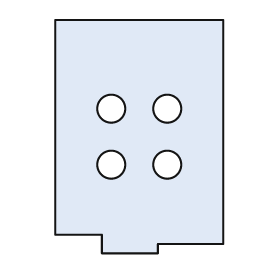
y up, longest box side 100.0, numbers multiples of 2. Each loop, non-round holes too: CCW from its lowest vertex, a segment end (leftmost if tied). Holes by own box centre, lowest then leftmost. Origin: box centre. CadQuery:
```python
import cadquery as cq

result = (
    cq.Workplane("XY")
    .moveTo(-16.0, -50.0)
    .lineTo(8.0, -50.0)
    .lineTo(8.0, -46.0)
    .lineTo(36.0, -46.0)
    .lineTo(36.0, 50.0)
    .lineTo(-36.0, 50.0)
    .lineTo(-36.0, -42.0)
    .lineTo(-16.0, -42.0)
    .close()
    .moveTo(-12.0, -12.0)
    .circle(6.0)
    .moveTo(12.0, -12.0)
    .circle(6.0)
    .moveTo(-12.0, 12.0)
    .circle(6.0)
    .moveTo(12.0, 12.0)
    .circle(6.0)
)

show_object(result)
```